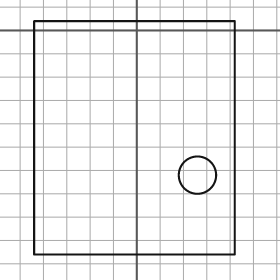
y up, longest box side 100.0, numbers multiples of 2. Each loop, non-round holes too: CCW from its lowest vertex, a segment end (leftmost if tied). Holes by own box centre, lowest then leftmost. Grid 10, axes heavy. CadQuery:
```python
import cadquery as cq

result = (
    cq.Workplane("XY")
    .moveTo(-44.0, -96.0)
    .lineTo(42.0, -96.0)
    .lineTo(42.0, 4.0)
    .lineTo(-44.0, 4.0)
    .close()
    .moveTo(26.0, -62.0)
    .circle(8.0)
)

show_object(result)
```